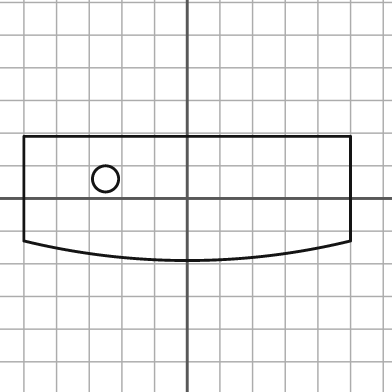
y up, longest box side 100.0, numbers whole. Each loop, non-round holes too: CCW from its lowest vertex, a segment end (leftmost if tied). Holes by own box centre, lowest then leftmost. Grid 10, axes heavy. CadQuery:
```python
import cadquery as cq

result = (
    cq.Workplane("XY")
    .moveTo(-50.0, -13.0)
    .threePointArc((0.0, -19.0), (50.0, -13.0))
    .lineTo(50.0, 19.0)
    .lineTo(-50.0, 19.0)
    .close()
    .moveTo(-25.0, 6.0)
    .circle(4.0)
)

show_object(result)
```